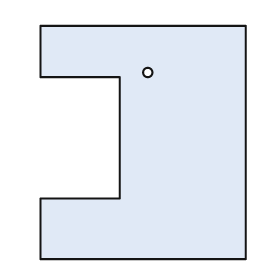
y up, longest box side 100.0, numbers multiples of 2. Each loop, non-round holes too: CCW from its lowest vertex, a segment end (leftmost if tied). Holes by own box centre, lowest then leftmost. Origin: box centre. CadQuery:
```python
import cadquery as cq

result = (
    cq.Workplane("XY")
    .moveTo(-44.0, -50.0)
    .lineTo(44.0, -50.0)
    .lineTo(44.0, 50.0)
    .lineTo(-44.0, 50.0)
    .lineTo(-44.0, 28.0)
    .lineTo(-10.0, 28.0)
    .lineTo(-10.0, -24.0)
    .lineTo(-44.0, -24.0)
    .close()
    .moveTo(2.0, 30.0)
    .circle(2.0)
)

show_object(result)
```